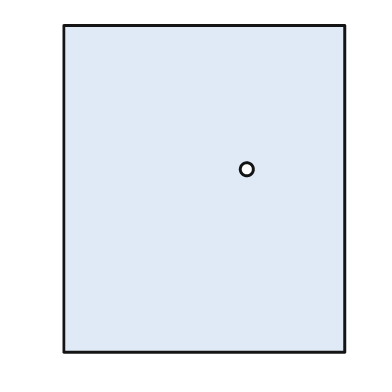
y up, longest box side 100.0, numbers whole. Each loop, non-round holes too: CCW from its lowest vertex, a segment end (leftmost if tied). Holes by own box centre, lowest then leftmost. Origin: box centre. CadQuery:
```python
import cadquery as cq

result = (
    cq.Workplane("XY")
    .moveTo(-43.0, -50.0)
    .lineTo(43.0, -50.0)
    .lineTo(43.0, 50.0)
    .lineTo(-43.0, 50.0)
    .close()
    .moveTo(13.0, 6.0)
    .circle(2.0)
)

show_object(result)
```